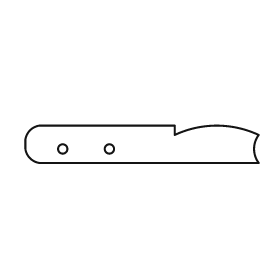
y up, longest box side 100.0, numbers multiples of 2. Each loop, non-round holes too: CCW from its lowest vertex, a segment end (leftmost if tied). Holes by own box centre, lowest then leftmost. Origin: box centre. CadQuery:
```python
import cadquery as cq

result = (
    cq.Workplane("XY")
    .moveTo(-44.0, -8.0)
    .lineTo(50.0, -8.0)
    .threePointArc((48.0, -2.0), (50.0, 4.0))
    .threePointArc((32.0, 8.0), (14.0, 4.0))
    .lineTo(14.0, 8.0)
    .lineTo(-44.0, 8.0)
    .threePointArc((-48.0, 6.0), (-50.0, 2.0))
    .lineTo(-50.0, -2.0)
    .threePointArc((-48.0, -6.0), (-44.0, -8.0))
    .close()
    .moveTo(-34.0, -2.0)
    .circle(2.0)
    .moveTo(-14.0, -2.0)
    .circle(2.0)
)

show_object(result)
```